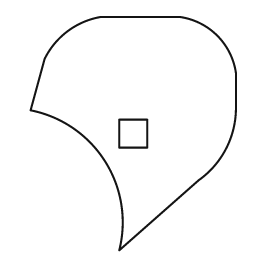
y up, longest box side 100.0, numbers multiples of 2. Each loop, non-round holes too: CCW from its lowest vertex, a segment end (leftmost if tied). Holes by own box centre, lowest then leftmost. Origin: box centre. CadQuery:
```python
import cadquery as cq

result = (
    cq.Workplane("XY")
    .moveTo(-6.0, -50.0)
    .lineTo(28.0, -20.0)
    .threePointArc((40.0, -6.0), (44.0, 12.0))
    .lineTo(44.0, 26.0)
    .threePointArc((36.0, 42.0), (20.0, 50.0))
    .lineTo(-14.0, 50.0)
    .threePointArc((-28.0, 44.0), (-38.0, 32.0))
    .lineTo(-44.0, 10.0)
    .threePointArc((-12.0, -12.0), (-6.0, -50.0))
    .close()
    .moveTo(-6.0, -6.0)
    .lineTo(6.0, -6.0)
    .lineTo(6.0, 6.0)
    .lineTo(-6.0, 6.0)
    .close()
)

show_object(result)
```